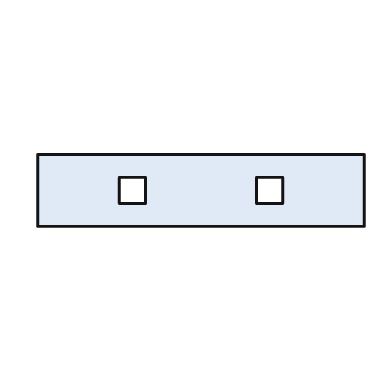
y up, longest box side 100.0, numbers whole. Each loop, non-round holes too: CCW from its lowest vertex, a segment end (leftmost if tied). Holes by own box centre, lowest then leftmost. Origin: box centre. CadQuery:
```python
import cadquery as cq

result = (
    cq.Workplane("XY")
    .moveTo(-50.0, -11.0)
    .lineTo(50.0, -11.0)
    .lineTo(50.0, 11.0)
    .lineTo(-50.0, 11.0)
    .close()
    .moveTo(-25.0, -4.0)
    .lineTo(-17.0, -4.0)
    .lineTo(-17.0, 4.0)
    .lineTo(-25.0, 4.0)
    .close()
    .moveTo(17.0, -4.0)
    .lineTo(25.0, -4.0)
    .lineTo(25.0, 4.0)
    .lineTo(17.0, 4.0)
    .close()
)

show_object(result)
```